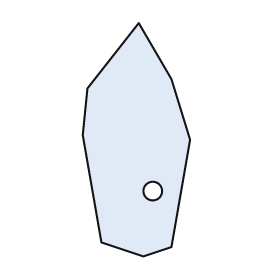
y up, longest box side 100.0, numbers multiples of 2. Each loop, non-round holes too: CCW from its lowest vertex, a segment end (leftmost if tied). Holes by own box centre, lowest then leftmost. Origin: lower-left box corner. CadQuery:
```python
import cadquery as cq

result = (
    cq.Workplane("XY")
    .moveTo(26.0, 0.0)
    .lineTo(38.0, 4.0)
    .lineTo(46.0, 50.0)
    .lineTo(38.0, 76.0)
    .lineTo(24.0, 100.0)
    .lineTo(2.0, 72.0)
    .lineTo(0.0, 52.0)
    .lineTo(8.0, 6.0)
    .close()
    .moveTo(30.0, 28.0)
    .circle(4.0)
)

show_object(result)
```